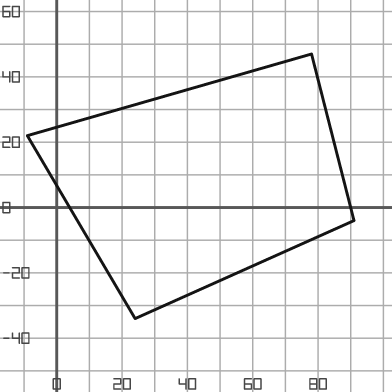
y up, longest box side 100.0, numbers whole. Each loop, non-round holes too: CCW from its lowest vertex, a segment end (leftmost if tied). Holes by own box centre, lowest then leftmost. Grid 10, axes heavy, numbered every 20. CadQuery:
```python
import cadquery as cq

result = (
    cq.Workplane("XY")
    .moveTo(24.0, -34.0)
    .lineTo(91.0, -4.0)
    .lineTo(78.0, 47.0)
    .lineTo(-9.0, 22.0)
    .close()
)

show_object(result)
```